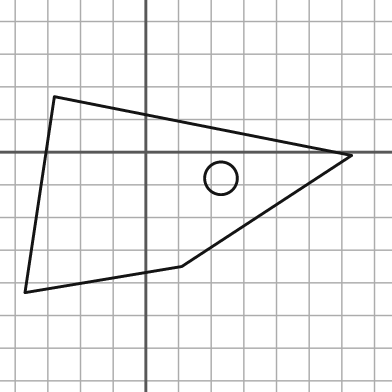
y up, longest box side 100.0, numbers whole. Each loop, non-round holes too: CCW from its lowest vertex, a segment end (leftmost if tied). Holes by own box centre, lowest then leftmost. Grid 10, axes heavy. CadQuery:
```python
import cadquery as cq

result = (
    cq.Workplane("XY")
    .moveTo(-37.0, -43.0)
    .lineTo(11.0, -35.0)
    .lineTo(63.0, -1.0)
    .lineTo(-28.0, 17.0)
    .close()
    .moveTo(23.0, -8.0)
    .circle(5.0)
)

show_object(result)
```